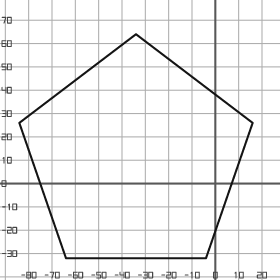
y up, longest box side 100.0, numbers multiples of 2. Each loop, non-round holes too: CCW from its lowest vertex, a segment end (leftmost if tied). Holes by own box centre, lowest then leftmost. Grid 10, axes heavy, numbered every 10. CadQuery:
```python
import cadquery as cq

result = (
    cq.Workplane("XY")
    .moveTo(-64.0, -32.0)
    .lineTo(-4.0, -32.0)
    .lineTo(16.0, 26.0)
    .lineTo(-34.0, 64.0)
    .lineTo(-84.0, 26.0)
    .close()
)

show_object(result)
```